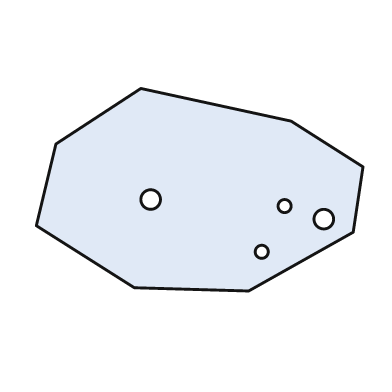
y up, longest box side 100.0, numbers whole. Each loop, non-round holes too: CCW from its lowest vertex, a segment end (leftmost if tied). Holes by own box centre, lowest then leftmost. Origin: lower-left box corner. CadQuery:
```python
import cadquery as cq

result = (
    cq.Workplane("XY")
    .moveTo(65.0, 0.0)
    .lineTo(97.0, 18.0)
    .lineTo(100.0, 38.0)
    .lineTo(78.0, 52.0)
    .lineTo(32.0, 62.0)
    .lineTo(6.0, 45.0)
    .lineTo(0.0, 20.0)
    .lineTo(30.0, 1.0)
    .close()
    .moveTo(69.0, 12.0)
    .circle(2.0)
    .moveTo(88.0, 22.0)
    .circle(3.0)
    .moveTo(76.0, 26.0)
    .circle(2.0)
    .moveTo(35.0, 28.0)
    .circle(3.0)
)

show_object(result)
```